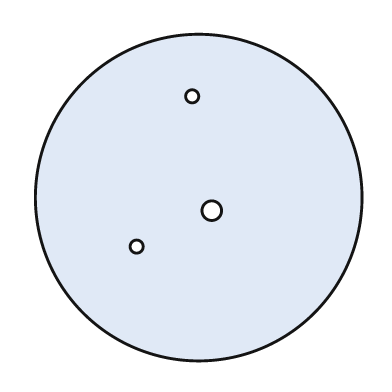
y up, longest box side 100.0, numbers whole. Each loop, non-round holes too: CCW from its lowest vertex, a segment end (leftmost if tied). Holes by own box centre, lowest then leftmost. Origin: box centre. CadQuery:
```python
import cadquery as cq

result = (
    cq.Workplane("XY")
    .moveTo(0.0, 0.0)
    .circle(50.0)
    .moveTo(-19.0, -15.0)
    .circle(2.0)
    .moveTo(4.0, -4.0)
    .circle(3.0)
    .moveTo(-2.0, 31.0)
    .circle(2.0)
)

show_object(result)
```